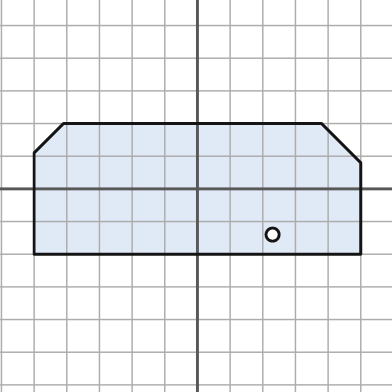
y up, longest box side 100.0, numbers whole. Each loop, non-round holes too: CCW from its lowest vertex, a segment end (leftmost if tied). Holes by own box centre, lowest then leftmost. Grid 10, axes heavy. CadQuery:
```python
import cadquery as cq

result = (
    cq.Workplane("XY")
    .moveTo(-50.0, -20.0)
    .lineTo(50.0, -20.0)
    .lineTo(50.0, 8.0)
    .lineTo(38.0, 20.0)
    .lineTo(-41.0, 20.0)
    .lineTo(-50.0, 11.0)
    .close()
    .moveTo(23.0, -14.0)
    .circle(2.0)
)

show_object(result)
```